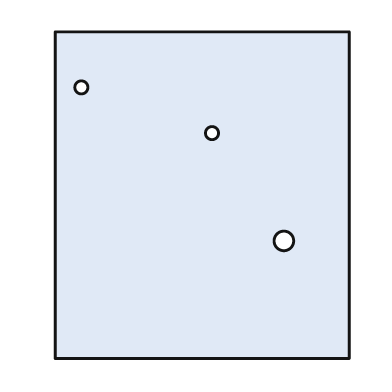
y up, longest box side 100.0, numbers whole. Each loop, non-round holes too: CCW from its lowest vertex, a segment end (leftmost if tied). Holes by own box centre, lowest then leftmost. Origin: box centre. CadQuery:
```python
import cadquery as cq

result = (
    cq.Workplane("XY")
    .moveTo(-45.0, -50.0)
    .lineTo(45.0, -50.0)
    .lineTo(45.0, 50.0)
    .lineTo(-45.0, 50.0)
    .close()
    .moveTo(25.0, -14.0)
    .circle(3.0)
    .moveTo(3.0, 19.0)
    .circle(2.0)
    .moveTo(-37.0, 33.0)
    .circle(2.0)
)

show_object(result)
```